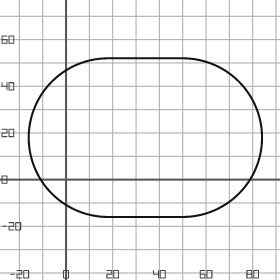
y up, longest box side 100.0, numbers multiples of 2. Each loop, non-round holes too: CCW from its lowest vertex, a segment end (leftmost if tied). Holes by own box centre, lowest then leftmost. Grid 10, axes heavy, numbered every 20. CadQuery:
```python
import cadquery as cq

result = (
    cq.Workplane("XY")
    .moveTo(18.0, -16.0)
    .lineTo(50.0, -16.0)
    .threePointArc((84.0, 18.0), (50.0, 52.0))
    .lineTo(18.0, 52.0)
    .threePointArc((-16.0, 18.0), (18.0, -16.0))
    .close()
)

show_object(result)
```